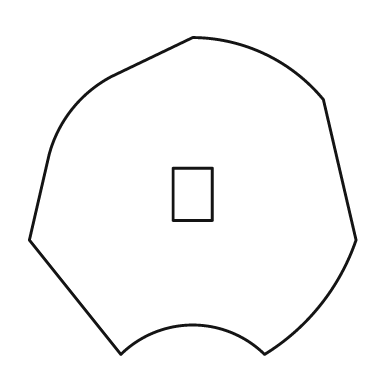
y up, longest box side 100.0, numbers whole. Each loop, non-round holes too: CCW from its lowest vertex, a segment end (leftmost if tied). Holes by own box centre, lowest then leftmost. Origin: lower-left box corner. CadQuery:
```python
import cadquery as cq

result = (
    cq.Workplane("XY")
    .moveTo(28.0, 0.0)
    .threePointArc((50.0, 9.0), (72.0, 0.0))
    .threePointArc((89.0, 15.0), (100.0, 35.0))
    .lineTo(90.0, 78.0)
    .threePointArc((72.0, 92.0), (50.0, 97.0))
    .lineTo(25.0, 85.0)
    .threePointArc((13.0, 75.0), (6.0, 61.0))
    .lineTo(0.0, 35.0)
    .close()
    .moveTo(44.0, 41.0)
    .lineTo(56.0, 41.0)
    .lineTo(56.0, 57.0)
    .lineTo(44.0, 57.0)
    .close()
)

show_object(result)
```